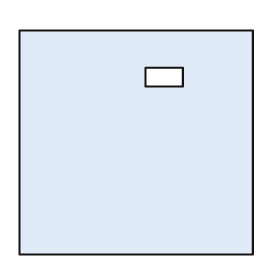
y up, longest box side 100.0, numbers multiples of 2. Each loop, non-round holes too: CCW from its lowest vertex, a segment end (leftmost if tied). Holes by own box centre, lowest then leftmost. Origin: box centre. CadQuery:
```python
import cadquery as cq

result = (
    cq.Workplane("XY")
    .moveTo(-50.0, -48.0)
    .lineTo(50.0, -48.0)
    .lineTo(50.0, 48.0)
    .lineTo(-50.0, 48.0)
    .close()
    .moveTo(4.0, 24.0)
    .lineTo(20.0, 24.0)
    .lineTo(20.0, 32.0)
    .lineTo(4.0, 32.0)
    .close()
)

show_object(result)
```